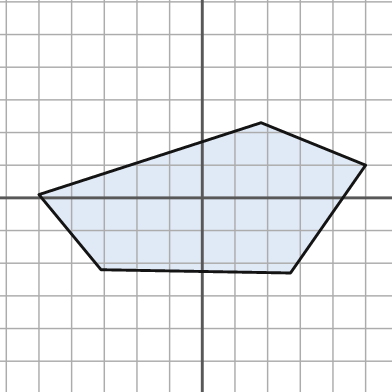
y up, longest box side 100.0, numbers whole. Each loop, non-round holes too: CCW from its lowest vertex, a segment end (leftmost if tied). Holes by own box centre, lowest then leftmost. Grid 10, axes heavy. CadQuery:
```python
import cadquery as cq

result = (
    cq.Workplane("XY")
    .moveTo(27.0, -23.0)
    .lineTo(50.0, 10.0)
    .lineTo(18.0, 23.0)
    .lineTo(-50.0, 1.0)
    .lineTo(-31.0, -22.0)
    .close()
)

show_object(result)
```